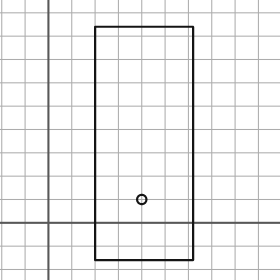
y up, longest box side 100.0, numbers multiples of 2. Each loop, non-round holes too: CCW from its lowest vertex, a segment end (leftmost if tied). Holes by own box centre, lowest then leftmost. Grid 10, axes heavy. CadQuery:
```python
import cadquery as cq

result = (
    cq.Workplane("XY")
    .moveTo(20.0, -16.0)
    .lineTo(62.0, -16.0)
    .lineTo(62.0, 84.0)
    .lineTo(20.0, 84.0)
    .close()
    .moveTo(40.0, 10.0)
    .circle(2.0)
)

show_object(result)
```